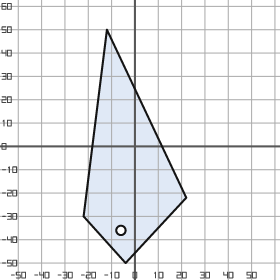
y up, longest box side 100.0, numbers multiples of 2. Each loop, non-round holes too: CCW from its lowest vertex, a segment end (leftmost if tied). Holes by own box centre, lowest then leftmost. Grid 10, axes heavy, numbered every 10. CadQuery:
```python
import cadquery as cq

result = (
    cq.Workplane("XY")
    .moveTo(-4.0, -50.0)
    .lineTo(22.0, -22.0)
    .lineTo(-12.0, 50.0)
    .lineTo(-22.0, -30.0)
    .close()
    .moveTo(-6.0, -36.0)
    .circle(2.0)
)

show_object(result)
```